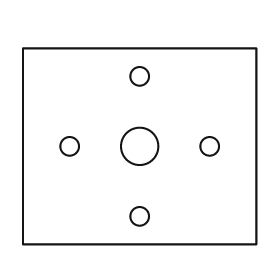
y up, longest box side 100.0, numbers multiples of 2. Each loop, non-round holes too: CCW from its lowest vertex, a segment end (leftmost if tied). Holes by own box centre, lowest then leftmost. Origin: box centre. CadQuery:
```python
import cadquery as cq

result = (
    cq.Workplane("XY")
    .moveTo(-50.0, -42.0)
    .lineTo(50.0, -42.0)
    .lineTo(50.0, 42.0)
    .lineTo(-50.0, 42.0)
    .close()
    .moveTo(0.0, -30.0)
    .circle(4.0)
    .moveTo(-30.0, 0.0)
    .circle(4.0)
    .moveTo(0.0, 0.0)
    .circle(8.0)
    .moveTo(30.0, 0.0)
    .circle(4.0)
    .moveTo(0.0, 30.0)
    .circle(4.0)
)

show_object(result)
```